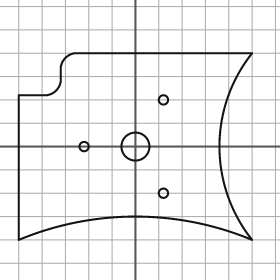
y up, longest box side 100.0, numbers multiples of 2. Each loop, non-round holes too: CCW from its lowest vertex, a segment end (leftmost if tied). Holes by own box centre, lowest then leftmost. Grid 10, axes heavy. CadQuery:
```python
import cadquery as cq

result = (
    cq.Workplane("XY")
    .moveTo(-50.0, -40.0)
    .threePointArc((0.0, -30.0), (50.0, -40.0))
    .threePointArc((36.0, 0.0), (50.0, 40.0))
    .lineTo(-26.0, 40.0)
    .threePointArc((-30.0, 38.0), (-32.0, 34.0))
    .lineTo(-32.0, 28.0)
    .threePointArc((-34.0, 24.0), (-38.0, 22.0))
    .lineTo(-50.0, 22.0)
    .close()
    .moveTo(12.0, -20.0)
    .circle(2.0)
    .moveTo(-22.0, 0.0)
    .circle(2.0)
    .moveTo(0.0, 0.0)
    .circle(6.0)
    .moveTo(12.0, 20.0)
    .circle(2.0)
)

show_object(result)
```